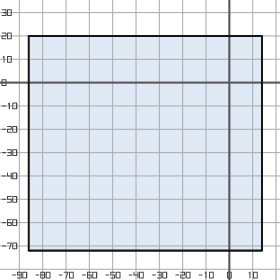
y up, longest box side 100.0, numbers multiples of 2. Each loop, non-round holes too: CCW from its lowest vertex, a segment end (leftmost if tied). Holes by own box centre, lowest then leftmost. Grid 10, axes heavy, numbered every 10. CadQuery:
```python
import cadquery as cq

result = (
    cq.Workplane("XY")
    .moveTo(-86.0, -72.0)
    .lineTo(14.0, -72.0)
    .lineTo(14.0, 20.0)
    .lineTo(-86.0, 20.0)
    .close()
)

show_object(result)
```